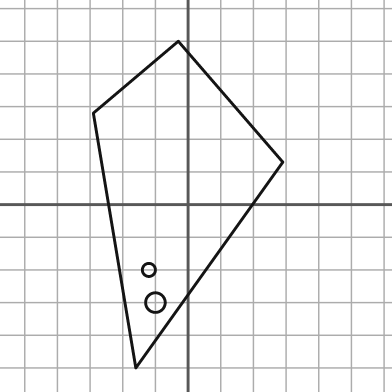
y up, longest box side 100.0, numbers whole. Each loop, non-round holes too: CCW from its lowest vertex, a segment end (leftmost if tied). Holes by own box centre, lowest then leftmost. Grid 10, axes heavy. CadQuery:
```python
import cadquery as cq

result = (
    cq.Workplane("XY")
    .moveTo(-16.0, -50.0)
    .lineTo(29.0, 13.0)
    .lineTo(-3.0, 50.0)
    .lineTo(-29.0, 28.0)
    .close()
    .moveTo(-10.0, -30.0)
    .circle(3.0)
    .moveTo(-12.0, -20.0)
    .circle(2.0)
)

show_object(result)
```